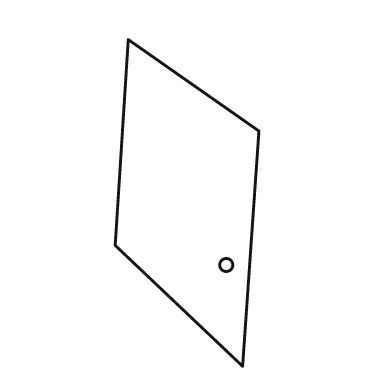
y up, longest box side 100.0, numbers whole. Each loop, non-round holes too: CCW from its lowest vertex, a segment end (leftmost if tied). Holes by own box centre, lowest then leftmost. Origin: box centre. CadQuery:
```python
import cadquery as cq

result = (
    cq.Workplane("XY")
    .moveTo(17.0, -50.0)
    .lineTo(22.0, 22.0)
    .lineTo(-18.0, 50.0)
    .lineTo(-22.0, -13.0)
    .close()
    .moveTo(12.0, -19.0)
    .circle(2.0)
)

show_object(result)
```